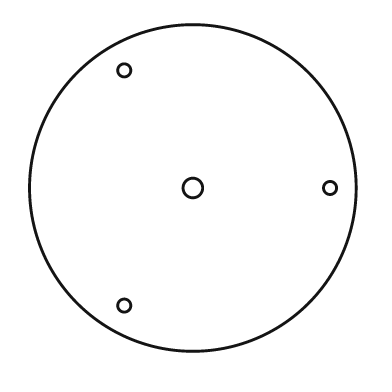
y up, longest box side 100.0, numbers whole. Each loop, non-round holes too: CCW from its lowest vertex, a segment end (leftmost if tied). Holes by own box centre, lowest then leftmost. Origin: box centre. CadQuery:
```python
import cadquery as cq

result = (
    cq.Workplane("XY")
    .moveTo(0.0, 0.0)
    .circle(50.0)
    .moveTo(-21.0, -36.0)
    .circle(2.0)
    .moveTo(0.0, 0.0)
    .circle(3.0)
    .moveTo(42.0, 0.0)
    .circle(2.0)
    .moveTo(-21.0, 36.0)
    .circle(2.0)
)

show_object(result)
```